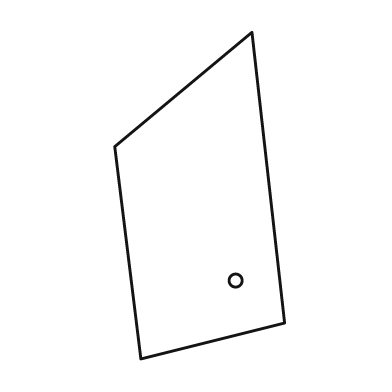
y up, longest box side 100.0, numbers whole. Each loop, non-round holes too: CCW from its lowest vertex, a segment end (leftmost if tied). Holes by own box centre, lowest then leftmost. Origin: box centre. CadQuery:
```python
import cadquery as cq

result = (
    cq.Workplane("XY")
    .moveTo(-18.0, -50.0)
    .lineTo(26.0, -39.0)
    .lineTo(16.0, 50.0)
    .lineTo(-26.0, 15.0)
    .close()
    .moveTo(11.0, -26.0)
    .circle(2.0)
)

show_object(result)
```